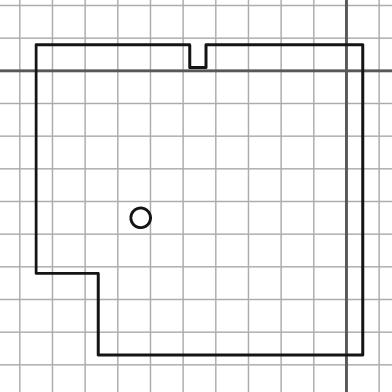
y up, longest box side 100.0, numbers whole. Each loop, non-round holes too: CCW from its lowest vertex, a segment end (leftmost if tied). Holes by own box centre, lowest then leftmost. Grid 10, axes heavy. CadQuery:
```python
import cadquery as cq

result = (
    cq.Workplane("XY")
    .moveTo(-76.0, -87.0)
    .lineTo(5.0, -87.0)
    .lineTo(5.0, 8.0)
    .lineTo(-43.0, 8.0)
    .lineTo(-43.0, 1.0)
    .lineTo(-48.0, 1.0)
    .lineTo(-48.0, 8.0)
    .lineTo(-95.0, 8.0)
    .lineTo(-95.0, -62.0)
    .lineTo(-76.0, -62.0)
    .close()
    .moveTo(-63.0, -45.0)
    .circle(3.0)
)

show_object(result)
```